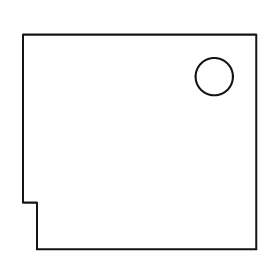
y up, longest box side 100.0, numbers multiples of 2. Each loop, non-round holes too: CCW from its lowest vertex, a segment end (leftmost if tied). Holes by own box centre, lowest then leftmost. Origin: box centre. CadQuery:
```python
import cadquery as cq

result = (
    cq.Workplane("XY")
    .moveTo(-44.0, -46.0)
    .lineTo(50.0, -46.0)
    .lineTo(50.0, 46.0)
    .lineTo(-50.0, 46.0)
    .lineTo(-50.0, -26.0)
    .lineTo(-44.0, -26.0)
    .close()
    .moveTo(32.0, 28.0)
    .circle(8.0)
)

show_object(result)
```